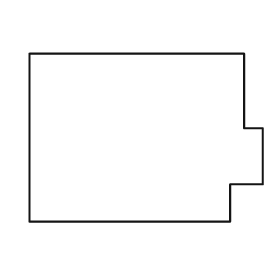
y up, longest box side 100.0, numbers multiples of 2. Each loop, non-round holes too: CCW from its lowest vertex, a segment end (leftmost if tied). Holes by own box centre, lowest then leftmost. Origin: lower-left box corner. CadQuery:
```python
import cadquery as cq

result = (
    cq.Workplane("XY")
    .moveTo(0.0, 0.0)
    .lineTo(86.0, 0.0)
    .lineTo(86.0, 16.0)
    .lineTo(100.0, 16.0)
    .lineTo(100.0, 40.0)
    .lineTo(92.0, 40.0)
    .lineTo(92.0, 72.0)
    .lineTo(0.0, 72.0)
    .close()
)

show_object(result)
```